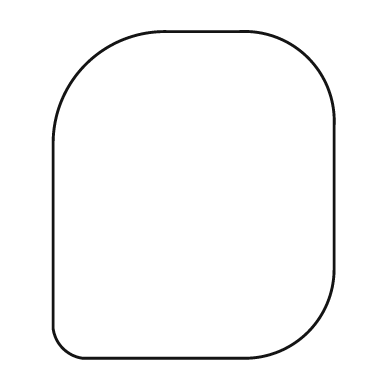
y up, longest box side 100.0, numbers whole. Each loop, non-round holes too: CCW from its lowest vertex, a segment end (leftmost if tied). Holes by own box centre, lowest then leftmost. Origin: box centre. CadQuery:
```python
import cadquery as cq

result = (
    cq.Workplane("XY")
    .moveTo(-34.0, -50.0)
    .lineTo(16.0, -50.0)
    .threePointArc((35.0, -42.0), (43.0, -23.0))
    .lineTo(43.0, 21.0)
    .threePointArc((35.0, 42.0), (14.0, 50.0))
    .lineTo(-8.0, 50.0)
    .threePointArc((-33.0, 40.0), (-43.0, 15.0))
    .lineTo(-43.0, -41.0)
    .threePointArc((-40.0, -47.0), (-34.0, -50.0))
    .close()
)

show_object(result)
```